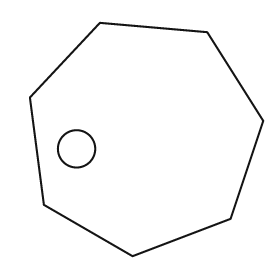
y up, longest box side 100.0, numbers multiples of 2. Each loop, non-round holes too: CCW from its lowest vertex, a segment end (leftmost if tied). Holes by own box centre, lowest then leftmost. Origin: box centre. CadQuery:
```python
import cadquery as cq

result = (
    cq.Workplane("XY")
    .moveTo(-6.0, -50.0)
    .lineTo(36.0, -34.0)
    .lineTo(50.0, 8.0)
    .lineTo(26.0, 46.0)
    .lineTo(-20.0, 50.0)
    .lineTo(-50.0, 18.0)
    .lineTo(-44.0, -28.0)
    .close()
    .moveTo(-30.0, -4.0)
    .circle(8.0)
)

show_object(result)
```